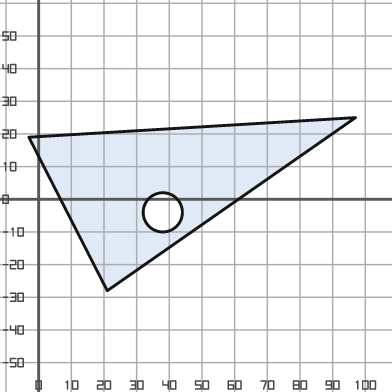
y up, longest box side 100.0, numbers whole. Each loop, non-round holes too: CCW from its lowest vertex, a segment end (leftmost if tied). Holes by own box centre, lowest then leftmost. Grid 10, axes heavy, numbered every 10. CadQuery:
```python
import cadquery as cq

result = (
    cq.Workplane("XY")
    .moveTo(21.0, -28.0)
    .lineTo(97.0, 25.0)
    .lineTo(-3.0, 19.0)
    .close()
    .moveTo(38.0, -4.0)
    .circle(6.0)
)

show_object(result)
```